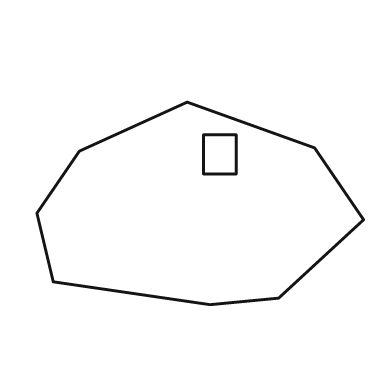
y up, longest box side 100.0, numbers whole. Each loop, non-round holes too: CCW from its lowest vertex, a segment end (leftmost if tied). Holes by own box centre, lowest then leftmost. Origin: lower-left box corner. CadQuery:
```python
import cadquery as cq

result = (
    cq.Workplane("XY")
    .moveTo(53.0, 0.0)
    .lineTo(74.0, 2.0)
    .lineTo(100.0, 26.0)
    .lineTo(85.0, 48.0)
    .lineTo(46.0, 62.0)
    .lineTo(13.0, 47.0)
    .lineTo(0.0, 28.0)
    .lineTo(5.0, 7.0)
    .close()
    .moveTo(51.0, 40.0)
    .lineTo(61.0, 40.0)
    .lineTo(61.0, 52.0)
    .lineTo(51.0, 52.0)
    .close()
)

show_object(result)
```